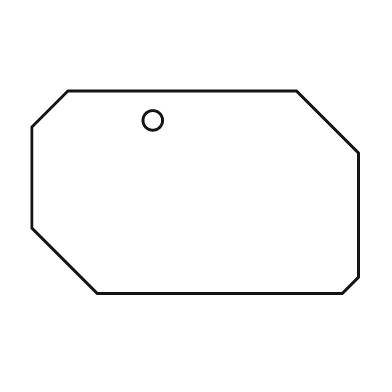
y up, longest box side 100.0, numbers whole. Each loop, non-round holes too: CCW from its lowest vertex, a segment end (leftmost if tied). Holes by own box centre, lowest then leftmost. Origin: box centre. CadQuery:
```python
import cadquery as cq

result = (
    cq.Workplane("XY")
    .moveTo(-30.0, -31.0)
    .lineTo(45.0, -31.0)
    .lineTo(50.0, -26.0)
    .lineTo(50.0, 12.0)
    .lineTo(31.0, 31.0)
    .lineTo(-39.0, 31.0)
    .lineTo(-50.0, 20.0)
    .lineTo(-50.0, -11.0)
    .close()
    .moveTo(-13.0, 22.0)
    .circle(3.0)
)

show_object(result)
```